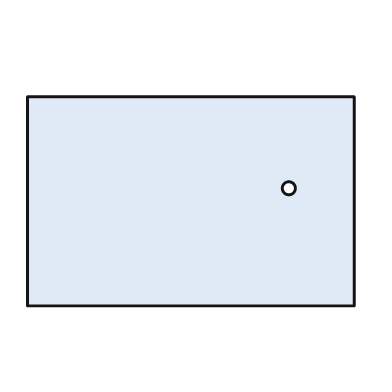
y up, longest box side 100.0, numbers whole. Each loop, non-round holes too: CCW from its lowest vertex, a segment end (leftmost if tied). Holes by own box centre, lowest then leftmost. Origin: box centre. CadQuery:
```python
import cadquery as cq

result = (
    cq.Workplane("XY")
    .moveTo(-50.0, -32.0)
    .lineTo(50.0, -32.0)
    .lineTo(50.0, 32.0)
    .lineTo(-50.0, 32.0)
    .close()
    .moveTo(30.0, 4.0)
    .circle(2.0)
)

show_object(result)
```